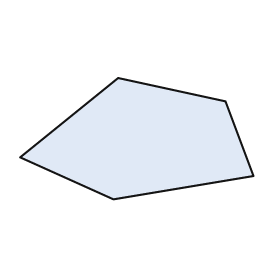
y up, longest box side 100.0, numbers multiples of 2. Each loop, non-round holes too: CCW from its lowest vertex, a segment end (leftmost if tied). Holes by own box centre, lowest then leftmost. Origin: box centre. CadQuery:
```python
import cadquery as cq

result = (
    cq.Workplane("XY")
    .moveTo(-10.0, -26.0)
    .lineTo(50.0, -16.0)
    .lineTo(38.0, 16.0)
    .lineTo(-8.0, 26.0)
    .lineTo(-50.0, -8.0)
    .close()
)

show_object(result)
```